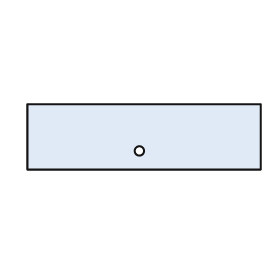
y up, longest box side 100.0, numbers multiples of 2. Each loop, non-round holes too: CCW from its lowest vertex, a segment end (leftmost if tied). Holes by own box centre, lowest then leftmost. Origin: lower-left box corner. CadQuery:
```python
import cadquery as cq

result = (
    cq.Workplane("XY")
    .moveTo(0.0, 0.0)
    .lineTo(100.0, 0.0)
    .lineTo(100.0, 28.0)
    .lineTo(0.0, 28.0)
    .close()
    .moveTo(48.0, 8.0)
    .circle(2.0)
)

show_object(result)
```